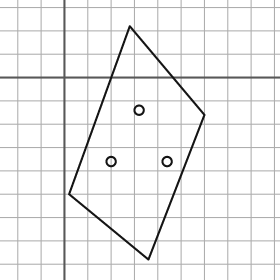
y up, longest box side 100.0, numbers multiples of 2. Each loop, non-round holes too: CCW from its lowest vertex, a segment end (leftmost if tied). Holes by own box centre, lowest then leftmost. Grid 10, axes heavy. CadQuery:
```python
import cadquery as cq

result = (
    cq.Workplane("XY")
    .moveTo(36.0, -78.0)
    .lineTo(60.0, -16.0)
    .lineTo(28.0, 22.0)
    .lineTo(2.0, -50.0)
    .close()
    .moveTo(20.0, -36.0)
    .circle(2.0)
    .moveTo(44.0, -36.0)
    .circle(2.0)
    .moveTo(32.0, -14.0)
    .circle(2.0)
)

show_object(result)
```